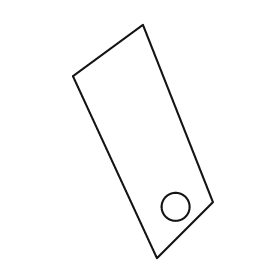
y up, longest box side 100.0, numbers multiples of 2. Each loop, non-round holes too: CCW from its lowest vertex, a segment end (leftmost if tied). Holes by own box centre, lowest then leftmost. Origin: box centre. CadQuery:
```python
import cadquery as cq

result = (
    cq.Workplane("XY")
    .moveTo(6.0, -50.0)
    .lineTo(30.0, -26.0)
    .lineTo(0.0, 50.0)
    .lineTo(-30.0, 28.0)
    .close()
    .moveTo(14.0, -28.0)
    .circle(6.0)
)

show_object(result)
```